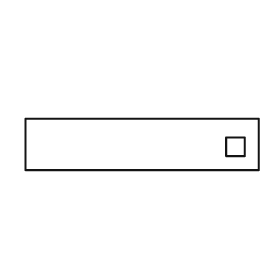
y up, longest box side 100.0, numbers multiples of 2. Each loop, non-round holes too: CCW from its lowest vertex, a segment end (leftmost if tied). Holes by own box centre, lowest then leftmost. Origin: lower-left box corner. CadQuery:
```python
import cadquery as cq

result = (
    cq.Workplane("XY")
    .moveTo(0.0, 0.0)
    .lineTo(100.0, 0.0)
    .lineTo(100.0, 22.0)
    .lineTo(0.0, 22.0)
    .close()
    .moveTo(86.0, 6.0)
    .lineTo(94.0, 6.0)
    .lineTo(94.0, 14.0)
    .lineTo(86.0, 14.0)
    .close()
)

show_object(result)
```